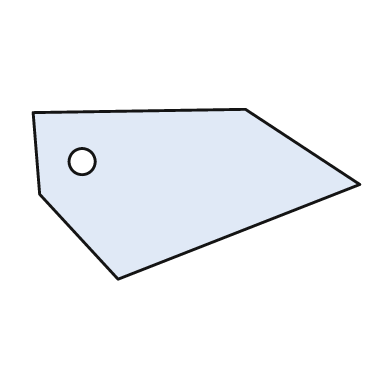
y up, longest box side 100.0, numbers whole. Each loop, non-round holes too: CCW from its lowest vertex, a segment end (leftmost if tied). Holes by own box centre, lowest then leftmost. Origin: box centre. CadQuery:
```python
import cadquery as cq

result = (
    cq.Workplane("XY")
    .moveTo(-24.0, -26.0)
    .lineTo(50.0, 3.0)
    .lineTo(15.0, 26.0)
    .lineTo(-50.0, 25.0)
    .lineTo(-48.0, 0.0)
    .close()
    .moveTo(-35.0, 10.0)
    .circle(4.0)
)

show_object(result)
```